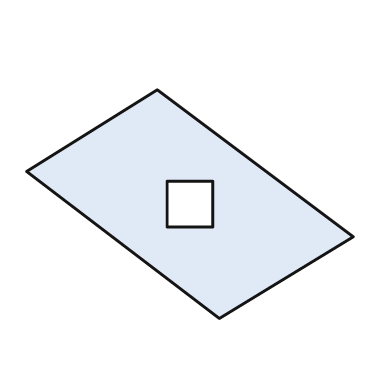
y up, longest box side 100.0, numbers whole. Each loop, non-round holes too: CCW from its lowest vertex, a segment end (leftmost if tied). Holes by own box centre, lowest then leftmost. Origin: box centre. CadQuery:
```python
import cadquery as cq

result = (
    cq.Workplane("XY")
    .moveTo(9.0, -35.0)
    .lineTo(50.0, -10.0)
    .lineTo(-10.0, 35.0)
    .lineTo(-50.0, 10.0)
    .close()
    .moveTo(-7.0, -7.0)
    .lineTo(7.0, -7.0)
    .lineTo(7.0, 7.0)
    .lineTo(-7.0, 7.0)
    .close()
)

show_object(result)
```